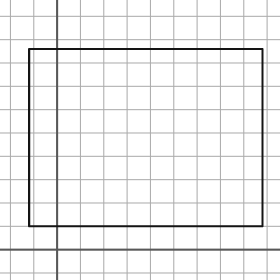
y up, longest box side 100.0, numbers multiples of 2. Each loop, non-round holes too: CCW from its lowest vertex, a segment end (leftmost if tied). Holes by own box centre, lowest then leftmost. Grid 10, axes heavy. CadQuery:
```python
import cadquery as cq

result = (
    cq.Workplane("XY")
    .moveTo(-12.0, 10.0)
    .lineTo(88.0, 10.0)
    .lineTo(88.0, 86.0)
    .lineTo(-12.0, 86.0)
    .close()
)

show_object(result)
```